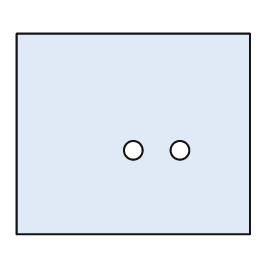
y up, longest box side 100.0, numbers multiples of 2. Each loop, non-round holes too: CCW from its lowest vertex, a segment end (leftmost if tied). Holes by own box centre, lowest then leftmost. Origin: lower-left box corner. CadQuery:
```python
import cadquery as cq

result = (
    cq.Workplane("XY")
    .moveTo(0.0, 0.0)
    .lineTo(100.0, 0.0)
    .lineTo(100.0, 86.0)
    .lineTo(0.0, 86.0)
    .close()
    .moveTo(50.0, 36.0)
    .circle(4.0)
    .moveTo(70.0, 36.0)
    .circle(4.0)
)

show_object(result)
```